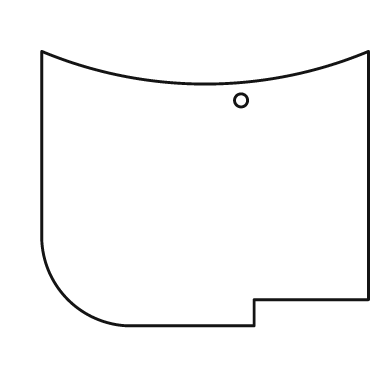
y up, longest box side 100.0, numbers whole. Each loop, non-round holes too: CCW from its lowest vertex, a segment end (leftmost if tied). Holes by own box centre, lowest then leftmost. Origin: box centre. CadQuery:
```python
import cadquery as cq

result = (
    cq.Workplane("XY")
    .moveTo(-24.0, -42.0)
    .lineTo(15.0, -42.0)
    .lineTo(15.0, -34.0)
    .lineTo(50.0, -34.0)
    .lineTo(50.0, 42.0)
    .threePointArc((0.0, 32.0), (-50.0, 42.0))
    .lineTo(-50.0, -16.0)
    .threePointArc((-42.0, -34.0), (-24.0, -42.0))
    .close()
    .moveTo(11.0, 27.0)
    .circle(2.0)
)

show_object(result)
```